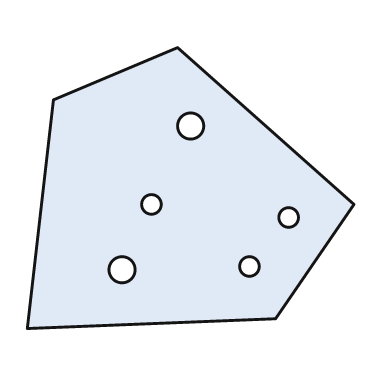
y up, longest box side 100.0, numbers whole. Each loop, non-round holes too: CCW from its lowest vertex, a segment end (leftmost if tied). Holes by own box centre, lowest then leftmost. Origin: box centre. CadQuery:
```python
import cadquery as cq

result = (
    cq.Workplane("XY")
    .moveTo(-50.0, -43.0)
    .lineTo(26.0, -40.0)
    .lineTo(50.0, -5.0)
    .lineTo(-4.0, 43.0)
    .lineTo(-42.0, 27.0)
    .close()
    .moveTo(-21.0, -25.0)
    .circle(4.0)
    .moveTo(18.0, -24.0)
    .circle(3.0)
    .moveTo(30.0, -9.0)
    .circle(3.0)
    .moveTo(-12.0, -5.0)
    .circle(3.0)
    .moveTo(0.0, 19.0)
    .circle(4.0)
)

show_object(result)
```